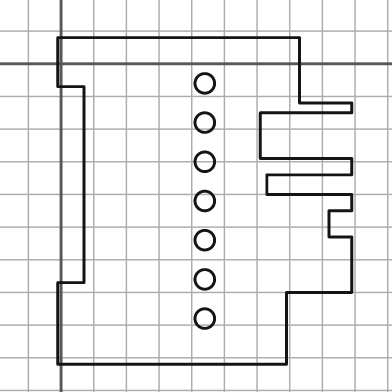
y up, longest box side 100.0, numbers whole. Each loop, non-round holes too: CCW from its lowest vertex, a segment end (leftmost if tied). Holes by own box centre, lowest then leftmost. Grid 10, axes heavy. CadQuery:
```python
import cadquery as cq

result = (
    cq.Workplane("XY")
    .moveTo(-1.0, -92.0)
    .lineTo(69.0, -92.0)
    .lineTo(69.0, -70.0)
    .lineTo(89.0, -70.0)
    .lineTo(89.0, -53.0)
    .lineTo(82.0, -53.0)
    .lineTo(82.0, -45.0)
    .lineTo(89.0, -45.0)
    .lineTo(89.0, -40.0)
    .lineTo(63.0, -40.0)
    .lineTo(63.0, -34.0)
    .lineTo(89.0, -34.0)
    .lineTo(89.0, -29.0)
    .lineTo(61.0, -29.0)
    .lineTo(61.0, -15.0)
    .lineTo(89.0, -15.0)
    .lineTo(89.0, -12.0)
    .lineTo(73.0, -12.0)
    .lineTo(73.0, 8.0)
    .lineTo(-1.0, 8.0)
    .lineTo(-1.0, -7.0)
    .lineTo(7.0, -7.0)
    .lineTo(7.0, -67.0)
    .lineTo(-1.0, -67.0)
    .close()
    .moveTo(44.0, -78.0)
    .circle(3.0)
    .moveTo(44.0, -66.0)
    .circle(3.0)
    .moveTo(44.0, -54.0)
    .circle(3.0)
    .moveTo(44.0, -42.0)
    .circle(3.0)
    .moveTo(44.0, -30.0)
    .circle(3.0)
    .moveTo(44.0, -18.0)
    .circle(3.0)
    .moveTo(44.0, -6.0)
    .circle(3.0)
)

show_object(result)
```